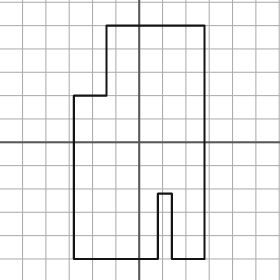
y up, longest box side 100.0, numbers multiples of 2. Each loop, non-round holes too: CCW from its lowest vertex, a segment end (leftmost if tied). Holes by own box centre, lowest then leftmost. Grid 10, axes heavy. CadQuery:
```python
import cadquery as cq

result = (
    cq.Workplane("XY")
    .moveTo(-28.0, -50.0)
    .lineTo(8.0, -50.0)
    .lineTo(8.0, -22.0)
    .lineTo(14.0, -22.0)
    .lineTo(14.0, -50.0)
    .lineTo(28.0, -50.0)
    .lineTo(28.0, 50.0)
    .lineTo(-14.0, 50.0)
    .lineTo(-14.0, 20.0)
    .lineTo(-28.0, 20.0)
    .close()
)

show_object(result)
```